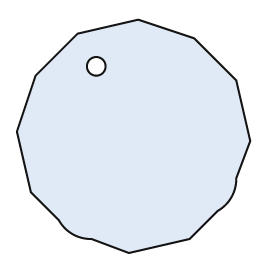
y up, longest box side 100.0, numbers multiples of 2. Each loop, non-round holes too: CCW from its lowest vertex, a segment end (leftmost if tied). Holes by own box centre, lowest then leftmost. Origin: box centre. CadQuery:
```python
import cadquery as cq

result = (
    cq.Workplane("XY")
    .moveTo(-2.0, -50.0)
    .lineTo(24.0, -44.0)
    .lineTo(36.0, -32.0)
    .threePointArc((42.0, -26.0), (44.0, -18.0))
    .lineTo(50.0, -2.0)
    .lineTo(44.0, 24.0)
    .lineTo(26.0, 42.0)
    .lineTo(2.0, 50.0)
    .lineTo(-24.0, 44.0)
    .lineTo(-42.0, 26.0)
    .lineTo(-50.0, 2.0)
    .lineTo(-44.0, -24.0)
    .lineTo(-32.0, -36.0)
    .threePointArc((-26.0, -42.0), (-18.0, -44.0))
    .close()
    .moveTo(-16.0, 30.0)
    .circle(4.0)
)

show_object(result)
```